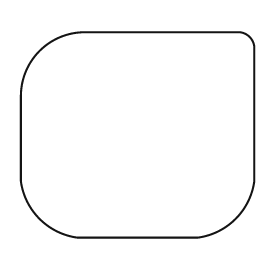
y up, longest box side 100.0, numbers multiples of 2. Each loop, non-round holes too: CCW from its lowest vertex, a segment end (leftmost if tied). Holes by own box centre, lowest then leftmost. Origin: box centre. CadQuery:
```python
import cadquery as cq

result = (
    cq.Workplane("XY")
    .moveTo(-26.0, -44.0)
    .lineTo(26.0, -44.0)
    .threePointArc((42.0, -36.0), (50.0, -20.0))
    .lineTo(50.0, 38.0)
    .threePointArc((48.0, 42.0), (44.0, 44.0))
    .lineTo(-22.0, 44.0)
    .threePointArc((-42.0, 36.0), (-50.0, 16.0))
    .lineTo(-50.0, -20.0)
    .threePointArc((-42.0, -36.0), (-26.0, -44.0))
    .close()
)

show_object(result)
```